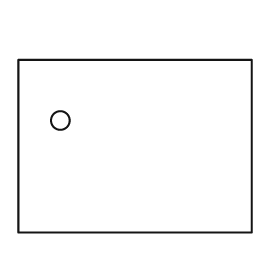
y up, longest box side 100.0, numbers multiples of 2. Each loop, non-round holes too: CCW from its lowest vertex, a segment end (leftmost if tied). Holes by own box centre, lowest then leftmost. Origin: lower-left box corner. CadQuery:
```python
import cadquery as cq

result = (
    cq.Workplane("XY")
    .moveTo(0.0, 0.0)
    .lineTo(100.0, 0.0)
    .lineTo(100.0, 74.0)
    .lineTo(0.0, 74.0)
    .close()
    .moveTo(18.0, 48.0)
    .circle(4.0)
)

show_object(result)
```